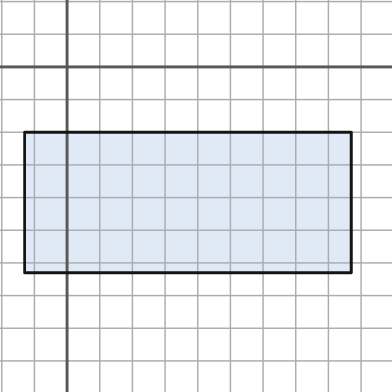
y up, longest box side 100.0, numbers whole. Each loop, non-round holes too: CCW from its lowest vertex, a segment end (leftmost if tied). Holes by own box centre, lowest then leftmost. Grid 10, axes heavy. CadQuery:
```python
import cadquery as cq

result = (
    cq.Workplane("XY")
    .moveTo(-13.0, -63.0)
    .lineTo(87.0, -63.0)
    .lineTo(87.0, -20.0)
    .lineTo(-13.0, -20.0)
    .close()
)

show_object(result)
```